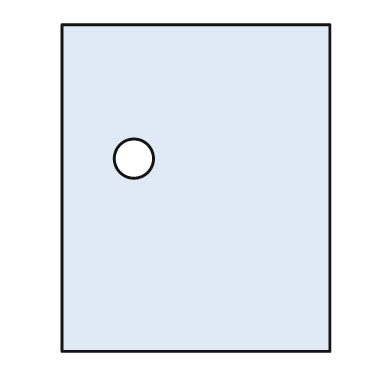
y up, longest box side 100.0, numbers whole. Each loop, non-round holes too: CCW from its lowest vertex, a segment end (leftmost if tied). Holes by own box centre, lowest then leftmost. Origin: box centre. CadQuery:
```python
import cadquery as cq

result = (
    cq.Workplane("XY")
    .moveTo(-41.0, -50.0)
    .lineTo(41.0, -50.0)
    .lineTo(41.0, 50.0)
    .lineTo(-41.0, 50.0)
    .close()
    .moveTo(-19.0, 9.0)
    .circle(6.0)
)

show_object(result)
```